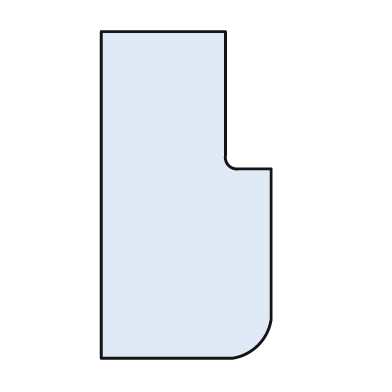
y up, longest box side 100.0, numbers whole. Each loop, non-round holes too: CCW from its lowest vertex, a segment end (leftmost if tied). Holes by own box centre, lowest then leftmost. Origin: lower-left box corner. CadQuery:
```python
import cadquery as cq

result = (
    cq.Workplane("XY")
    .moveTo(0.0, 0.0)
    .lineTo(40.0, 0.0)
    .threePointArc((48.0, 4.0), (52.0, 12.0))
    .lineTo(52.0, 58.0)
    .lineTo(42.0, 58.0)
    .threePointArc((39.0, 59.0), (38.0, 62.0))
    .lineTo(38.0, 100.0)
    .lineTo(0.0, 100.0)
    .close()
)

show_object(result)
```